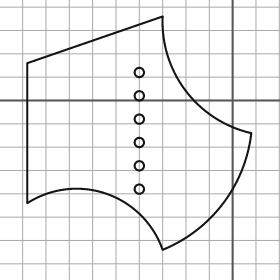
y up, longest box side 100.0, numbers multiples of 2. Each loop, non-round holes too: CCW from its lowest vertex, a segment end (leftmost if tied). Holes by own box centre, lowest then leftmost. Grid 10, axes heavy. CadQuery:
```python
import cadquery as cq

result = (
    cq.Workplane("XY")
    .moveTo(-30.0, -64.0)
    .threePointArc((-4.0, -44.0), (8.0, -14.0))
    .threePointArc((-20.0, 4.0), (-30.0, 36.0))
    .lineTo(-88.0, 16.0)
    .lineTo(-88.0, -44.0)
    .threePointArc((-54.0, -40.0), (-30.0, -64.0))
    .close()
    .moveTo(-40.0, -38.0)
    .circle(2.0)
    .moveTo(-40.0, -28.0)
    .circle(2.0)
    .moveTo(-40.0, -18.0)
    .circle(2.0)
    .moveTo(-40.0, -8.0)
    .circle(2.0)
    .moveTo(-40.0, 2.0)
    .circle(2.0)
    .moveTo(-40.0, 12.0)
    .circle(2.0)
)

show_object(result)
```